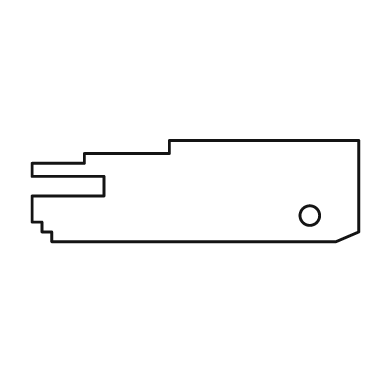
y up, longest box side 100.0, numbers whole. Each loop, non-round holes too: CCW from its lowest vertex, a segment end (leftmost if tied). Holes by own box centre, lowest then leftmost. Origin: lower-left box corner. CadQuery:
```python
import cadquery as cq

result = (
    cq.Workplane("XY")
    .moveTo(6.0, 0.0)
    .lineTo(93.0, 0.0)
    .lineTo(100.0, 3.0)
    .lineTo(100.0, 31.0)
    .lineTo(42.0, 31.0)
    .lineTo(42.0, 27.0)
    .lineTo(16.0, 27.0)
    .lineTo(16.0, 24.0)
    .lineTo(0.0, 24.0)
    .lineTo(0.0, 20.0)
    .lineTo(22.0, 20.0)
    .lineTo(22.0, 14.0)
    .lineTo(0.0, 14.0)
    .lineTo(0.0, 6.0)
    .lineTo(3.0, 6.0)
    .lineTo(3.0, 3.0)
    .lineTo(6.0, 3.0)
    .close()
    .moveTo(85.0, 8.0)
    .circle(3.0)
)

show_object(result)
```